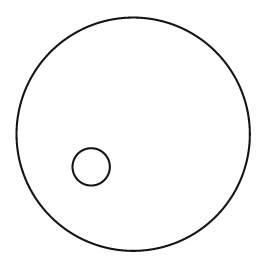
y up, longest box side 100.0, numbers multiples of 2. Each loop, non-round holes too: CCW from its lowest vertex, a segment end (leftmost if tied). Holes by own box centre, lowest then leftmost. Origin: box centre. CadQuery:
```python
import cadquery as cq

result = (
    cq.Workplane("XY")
    .moveTo(0.0, 0.0)
    .circle(50.0)
    .moveTo(-18.0, -14.0)
    .circle(8.0)
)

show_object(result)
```